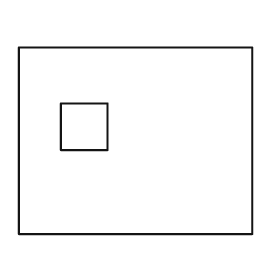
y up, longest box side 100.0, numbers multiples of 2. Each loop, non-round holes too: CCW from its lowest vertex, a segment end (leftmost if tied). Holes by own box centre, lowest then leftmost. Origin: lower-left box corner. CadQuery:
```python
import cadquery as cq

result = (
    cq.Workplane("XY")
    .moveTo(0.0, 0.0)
    .lineTo(100.0, 0.0)
    .lineTo(100.0, 80.0)
    .lineTo(0.0, 80.0)
    .close()
    .moveTo(18.0, 36.0)
    .lineTo(38.0, 36.0)
    .lineTo(38.0, 56.0)
    .lineTo(18.0, 56.0)
    .close()
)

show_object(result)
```